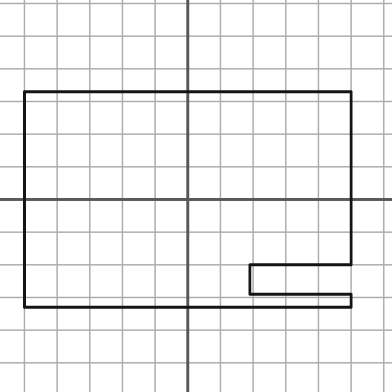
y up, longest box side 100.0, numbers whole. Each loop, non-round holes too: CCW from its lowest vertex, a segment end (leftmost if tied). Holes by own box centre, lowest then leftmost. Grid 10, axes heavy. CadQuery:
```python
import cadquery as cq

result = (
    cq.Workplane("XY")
    .moveTo(-50.0, -33.0)
    .lineTo(50.0, -33.0)
    .lineTo(50.0, -29.0)
    .lineTo(19.0, -29.0)
    .lineTo(19.0, -20.0)
    .lineTo(50.0, -20.0)
    .lineTo(50.0, 33.0)
    .lineTo(-50.0, 33.0)
    .close()
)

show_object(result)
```